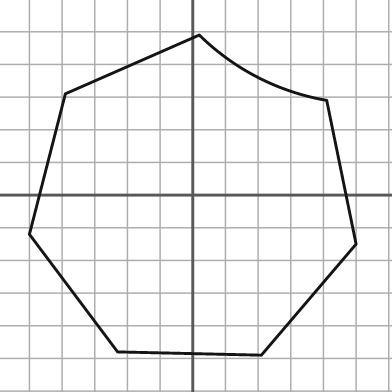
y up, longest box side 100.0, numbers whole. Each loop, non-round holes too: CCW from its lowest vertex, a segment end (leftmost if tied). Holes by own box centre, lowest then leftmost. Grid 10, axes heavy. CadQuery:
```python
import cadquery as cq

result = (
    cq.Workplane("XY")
    .moveTo(21.0, -49.0)
    .lineTo(50.0, -15.0)
    .lineTo(41.0, 29.0)
    .threePointArc((20.0, 36.0), (2.0, 49.0))
    .lineTo(-39.0, 31.0)
    .lineTo(-50.0, -12.0)
    .lineTo(-23.0, -48.0)
    .close()
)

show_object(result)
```